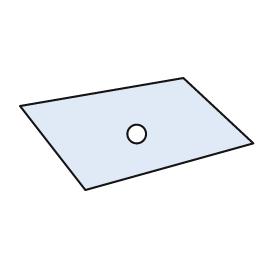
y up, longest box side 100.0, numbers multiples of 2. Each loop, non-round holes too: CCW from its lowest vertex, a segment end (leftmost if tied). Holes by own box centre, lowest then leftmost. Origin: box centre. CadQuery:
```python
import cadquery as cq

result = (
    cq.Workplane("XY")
    .moveTo(-22.0, -24.0)
    .lineTo(50.0, -4.0)
    .lineTo(20.0, 24.0)
    .lineTo(-50.0, 12.0)
    .close()
    .moveTo(0.0, 0.0)
    .circle(4.0)
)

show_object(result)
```